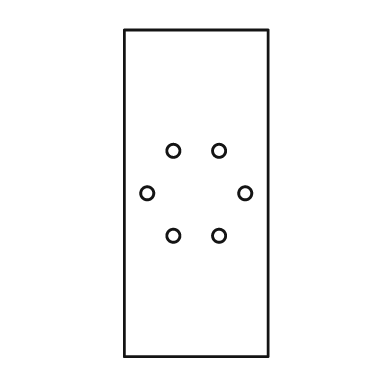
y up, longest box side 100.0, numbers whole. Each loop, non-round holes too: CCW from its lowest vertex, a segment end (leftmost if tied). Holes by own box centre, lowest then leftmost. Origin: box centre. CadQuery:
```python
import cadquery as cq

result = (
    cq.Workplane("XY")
    .moveTo(-22.0, -50.0)
    .lineTo(22.0, -50.0)
    .lineTo(22.0, 50.0)
    .lineTo(-22.0, 50.0)
    .close()
    .moveTo(-7.0, -13.0)
    .circle(2.0)
    .moveTo(7.0, -13.0)
    .circle(2.0)
    .moveTo(-15.0, 0.0)
    .circle(2.0)
    .moveTo(15.0, 0.0)
    .circle(2.0)
    .moveTo(-7.0, 13.0)
    .circle(2.0)
    .moveTo(7.0, 13.0)
    .circle(2.0)
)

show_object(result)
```